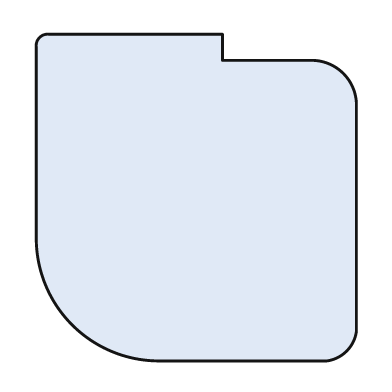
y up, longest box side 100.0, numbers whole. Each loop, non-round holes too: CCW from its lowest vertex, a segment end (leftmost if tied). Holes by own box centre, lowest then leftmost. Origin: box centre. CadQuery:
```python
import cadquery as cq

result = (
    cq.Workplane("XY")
    .moveTo(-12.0, -50.0)
    .lineTo(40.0, -50.0)
    .threePointArc((46.0, -47.0), (49.0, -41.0))
    .lineTo(49.0, 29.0)
    .threePointArc((45.0, 38.0), (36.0, 42.0))
    .lineTo(8.0, 42.0)
    .lineTo(8.0, 50.0)
    .lineTo(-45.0, 50.0)
    .threePointArc((-48.0, 49.0), (-49.0, 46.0))
    .lineTo(-49.0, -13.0)
    .threePointArc((-38.0, -39.0), (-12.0, -50.0))
    .close()
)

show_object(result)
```